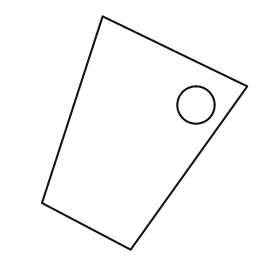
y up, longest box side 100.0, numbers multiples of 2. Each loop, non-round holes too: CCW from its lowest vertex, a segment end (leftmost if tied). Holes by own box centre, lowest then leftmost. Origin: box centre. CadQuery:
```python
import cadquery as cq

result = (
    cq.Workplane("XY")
    .moveTo(-6.0, -50.0)
    .lineTo(44.0, 20.0)
    .lineTo(-18.0, 50.0)
    .lineTo(-44.0, -30.0)
    .close()
    .moveTo(22.0, 12.0)
    .circle(8.0)
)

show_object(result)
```